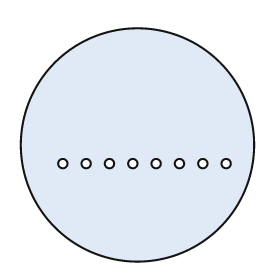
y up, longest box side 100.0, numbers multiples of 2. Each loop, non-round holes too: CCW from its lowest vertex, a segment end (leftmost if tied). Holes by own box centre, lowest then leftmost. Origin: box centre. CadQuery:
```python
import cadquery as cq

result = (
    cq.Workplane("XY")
    .moveTo(0.0, 0.0)
    .circle(50.0)
    .moveTo(-32.0, -8.0)
    .circle(2.0)
    .moveTo(-22.0, -8.0)
    .circle(2.0)
    .moveTo(-12.0, -8.0)
    .circle(2.0)
    .moveTo(-2.0, -8.0)
    .circle(2.0)
    .moveTo(8.0, -8.0)
    .circle(2.0)
    .moveTo(18.0, -8.0)
    .circle(2.0)
    .moveTo(28.0, -8.0)
    .circle(2.0)
    .moveTo(38.0, -8.0)
    .circle(2.0)
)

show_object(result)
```